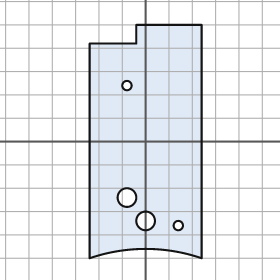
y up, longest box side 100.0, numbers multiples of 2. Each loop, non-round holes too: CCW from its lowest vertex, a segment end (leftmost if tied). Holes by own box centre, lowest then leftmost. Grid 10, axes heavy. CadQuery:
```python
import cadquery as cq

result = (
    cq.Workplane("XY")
    .moveTo(-24.0, -50.0)
    .threePointArc((0.0, -46.0), (24.0, -50.0))
    .lineTo(24.0, 50.0)
    .lineTo(-4.0, 50.0)
    .lineTo(-4.0, 42.0)
    .lineTo(-24.0, 42.0)
    .close()
    .moveTo(14.0, -36.0)
    .circle(2.0)
    .moveTo(0.0, -34.0)
    .circle(4.0)
    .moveTo(-8.0, -24.0)
    .circle(4.0)
    .moveTo(-8.0, 24.0)
    .circle(2.0)
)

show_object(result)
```